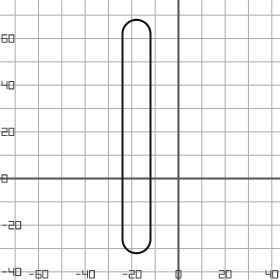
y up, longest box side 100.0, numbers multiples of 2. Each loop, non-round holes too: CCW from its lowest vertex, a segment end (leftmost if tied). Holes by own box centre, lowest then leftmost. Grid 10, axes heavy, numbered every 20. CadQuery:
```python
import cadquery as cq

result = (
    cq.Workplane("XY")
    .moveTo(-24.0, -26.0)
    .threePointArc((-18.0, -32.0), (-12.0, -26.0))
    .lineTo(-12.0, 62.0)
    .threePointArc((-18.0, 68.0), (-24.0, 62.0))
    .close()
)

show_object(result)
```